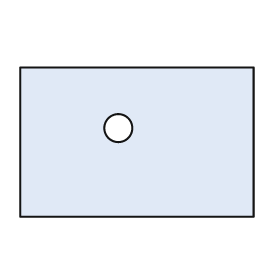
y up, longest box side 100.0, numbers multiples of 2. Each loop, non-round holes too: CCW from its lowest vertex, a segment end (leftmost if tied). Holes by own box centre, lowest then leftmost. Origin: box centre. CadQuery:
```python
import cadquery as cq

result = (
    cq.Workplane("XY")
    .moveTo(-50.0, -32.0)
    .lineTo(50.0, -32.0)
    .lineTo(50.0, 32.0)
    .lineTo(-50.0, 32.0)
    .close()
    .moveTo(-8.0, 6.0)
    .circle(6.0)
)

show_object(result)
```